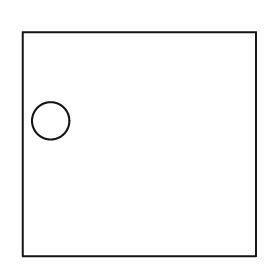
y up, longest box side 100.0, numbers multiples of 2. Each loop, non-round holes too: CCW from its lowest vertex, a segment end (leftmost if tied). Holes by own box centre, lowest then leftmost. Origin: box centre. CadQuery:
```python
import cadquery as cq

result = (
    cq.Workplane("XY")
    .moveTo(-50.0, -48.0)
    .lineTo(50.0, -48.0)
    .lineTo(50.0, 48.0)
    .lineTo(-50.0, 48.0)
    .close()
    .moveTo(-38.0, 10.0)
    .circle(8.0)
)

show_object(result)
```